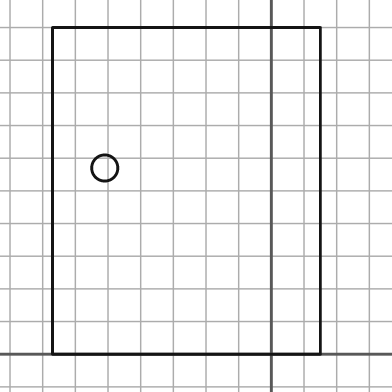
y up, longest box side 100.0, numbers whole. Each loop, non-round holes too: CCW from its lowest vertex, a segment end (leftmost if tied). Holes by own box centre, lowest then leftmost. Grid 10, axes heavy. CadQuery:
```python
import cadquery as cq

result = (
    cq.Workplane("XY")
    .moveTo(-67.0, 0.0)
    .lineTo(15.0, 0.0)
    .lineTo(15.0, 100.0)
    .lineTo(-67.0, 100.0)
    .close()
    .moveTo(-51.0, 57.0)
    .circle(4.0)
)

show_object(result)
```